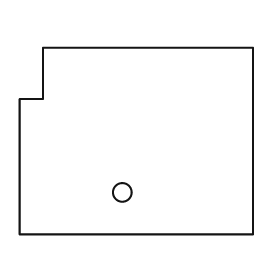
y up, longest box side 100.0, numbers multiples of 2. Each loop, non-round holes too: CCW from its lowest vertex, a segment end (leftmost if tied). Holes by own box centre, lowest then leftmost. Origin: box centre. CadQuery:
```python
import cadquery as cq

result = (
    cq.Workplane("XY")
    .moveTo(-50.0, -40.0)
    .lineTo(50.0, -40.0)
    .lineTo(50.0, 40.0)
    .lineTo(-40.0, 40.0)
    .lineTo(-40.0, 18.0)
    .lineTo(-50.0, 18.0)
    .close()
    .moveTo(-6.0, -22.0)
    .circle(4.0)
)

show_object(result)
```